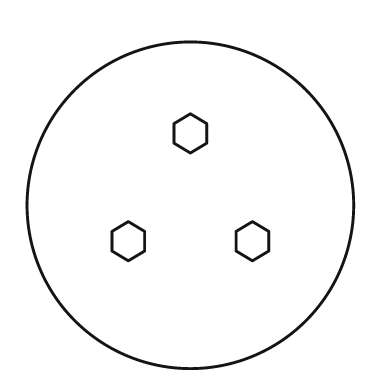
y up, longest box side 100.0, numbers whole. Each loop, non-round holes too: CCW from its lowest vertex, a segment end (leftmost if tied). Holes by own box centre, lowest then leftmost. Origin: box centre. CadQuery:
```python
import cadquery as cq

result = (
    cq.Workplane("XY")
    .moveTo(0.0, 0.0)
    .circle(50.0)
    .moveTo(-19.0, -17.0)
    .lineTo(-14.0, -14.0)
    .lineTo(-14.0, -8.0)
    .lineTo(-19.0, -5.0)
    .lineTo(-24.0, -8.0)
    .lineTo(-24.0, -14.0)
    .close()
    .moveTo(19.0, -17.0)
    .lineTo(24.0, -14.0)
    .lineTo(24.0, -8.0)
    .lineTo(19.0, -5.0)
    .lineTo(14.0, -8.0)
    .lineTo(14.0, -14.0)
    .close()
    .moveTo(0.0, 16.0)
    .lineTo(5.0, 19.0)
    .lineTo(5.0, 25.0)
    .lineTo(0.0, 28.0)
    .lineTo(-5.0, 25.0)
    .lineTo(-5.0, 19.0)
    .close()
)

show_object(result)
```